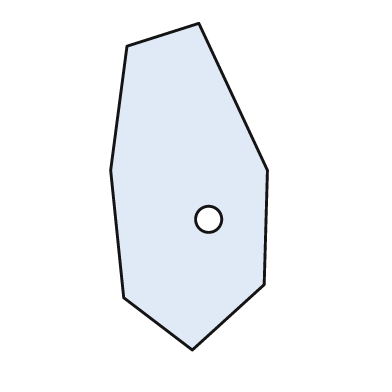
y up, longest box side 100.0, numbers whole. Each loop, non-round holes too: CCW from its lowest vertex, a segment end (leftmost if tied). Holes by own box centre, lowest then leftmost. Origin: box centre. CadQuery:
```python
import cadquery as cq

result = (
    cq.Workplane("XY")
    .moveTo(1.0, -50.0)
    .lineTo(23.0, -30.0)
    .lineTo(24.0, 5.0)
    .lineTo(3.0, 50.0)
    .lineTo(-19.0, 43.0)
    .lineTo(-24.0, 5.0)
    .lineTo(-20.0, -34.0)
    .close()
    .moveTo(6.0, -10.0)
    .circle(4.0)
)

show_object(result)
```